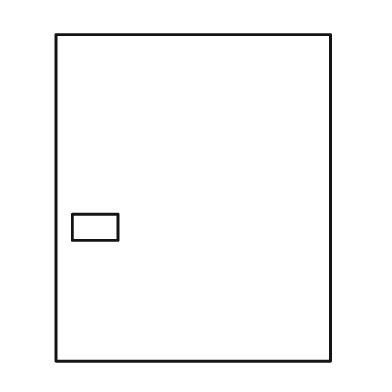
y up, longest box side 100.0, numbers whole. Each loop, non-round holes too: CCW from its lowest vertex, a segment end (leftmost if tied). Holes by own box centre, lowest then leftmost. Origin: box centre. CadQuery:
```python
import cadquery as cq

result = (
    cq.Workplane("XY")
    .moveTo(-42.0, -50.0)
    .lineTo(42.0, -50.0)
    .lineTo(42.0, 50.0)
    .lineTo(-42.0, 50.0)
    .close()
    .moveTo(-37.0, -13.0)
    .lineTo(-23.0, -13.0)
    .lineTo(-23.0, -5.0)
    .lineTo(-37.0, -5.0)
    .close()
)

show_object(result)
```